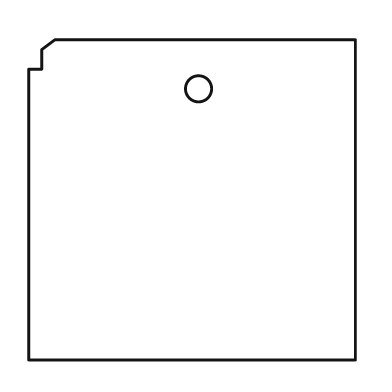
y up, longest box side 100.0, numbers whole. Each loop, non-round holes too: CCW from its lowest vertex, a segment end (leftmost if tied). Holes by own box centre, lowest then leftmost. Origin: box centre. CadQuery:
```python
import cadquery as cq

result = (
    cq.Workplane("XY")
    .moveTo(-50.0, -49.0)
    .lineTo(50.0, -49.0)
    .lineTo(50.0, 49.0)
    .lineTo(-42.0, 49.0)
    .lineTo(-46.0, 46.0)
    .lineTo(-46.0, 40.0)
    .lineTo(-50.0, 40.0)
    .close()
    .moveTo(2.0, 34.0)
    .circle(4.0)
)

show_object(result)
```